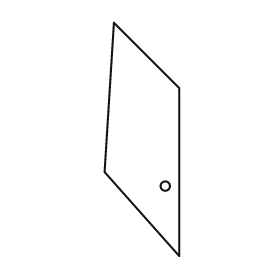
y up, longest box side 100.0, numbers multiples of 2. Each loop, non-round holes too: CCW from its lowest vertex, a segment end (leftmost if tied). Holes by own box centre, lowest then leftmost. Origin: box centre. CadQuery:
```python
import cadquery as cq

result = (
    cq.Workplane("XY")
    .moveTo(16.0, -50.0)
    .lineTo(16.0, 22.0)
    .lineTo(-12.0, 50.0)
    .lineTo(-16.0, -14.0)
    .close()
    .moveTo(10.0, -20.0)
    .circle(2.0)
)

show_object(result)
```